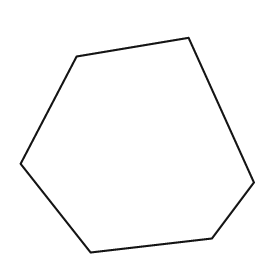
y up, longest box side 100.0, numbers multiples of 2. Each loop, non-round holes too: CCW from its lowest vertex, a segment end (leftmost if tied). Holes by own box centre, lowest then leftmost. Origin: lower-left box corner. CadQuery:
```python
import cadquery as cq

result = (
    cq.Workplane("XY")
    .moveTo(30.0, 0.0)
    .lineTo(82.0, 6.0)
    .lineTo(100.0, 30.0)
    .lineTo(72.0, 92.0)
    .lineTo(24.0, 84.0)
    .lineTo(0.0, 38.0)
    .close()
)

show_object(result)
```